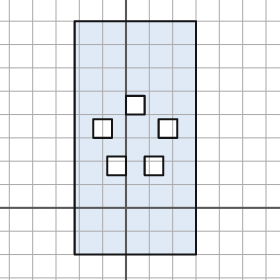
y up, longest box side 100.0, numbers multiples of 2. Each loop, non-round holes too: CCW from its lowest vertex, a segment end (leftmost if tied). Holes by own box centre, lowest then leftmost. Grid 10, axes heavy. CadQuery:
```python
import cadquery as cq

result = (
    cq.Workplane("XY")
    .moveTo(-22.0, -20.0)
    .lineTo(30.0, -20.0)
    .lineTo(30.0, 80.0)
    .lineTo(-22.0, 80.0)
    .close()
    .moveTo(-8.0, 14.0)
    .lineTo(0.0, 14.0)
    .lineTo(0.0, 22.0)
    .lineTo(-8.0, 22.0)
    .close()
    .moveTo(8.0, 14.0)
    .lineTo(16.0, 14.0)
    .lineTo(16.0, 22.0)
    .lineTo(8.0, 22.0)
    .close()
    .moveTo(-14.0, 30.0)
    .lineTo(-6.0, 30.0)
    .lineTo(-6.0, 38.0)
    .lineTo(-14.0, 38.0)
    .close()
    .moveTo(14.0, 30.0)
    .lineTo(22.0, 30.0)
    .lineTo(22.0, 38.0)
    .lineTo(14.0, 38.0)
    .close()
    .moveTo(0.0, 40.0)
    .lineTo(8.0, 40.0)
    .lineTo(8.0, 48.0)
    .lineTo(0.0, 48.0)
    .close()
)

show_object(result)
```